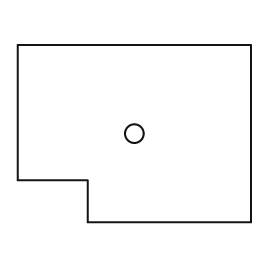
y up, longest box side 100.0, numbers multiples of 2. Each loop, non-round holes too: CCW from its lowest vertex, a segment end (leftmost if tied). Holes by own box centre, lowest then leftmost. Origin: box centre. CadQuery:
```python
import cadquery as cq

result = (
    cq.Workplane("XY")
    .moveTo(-20.0, -38.0)
    .lineTo(50.0, -38.0)
    .lineTo(50.0, 38.0)
    .lineTo(-50.0, 38.0)
    .lineTo(-50.0, -20.0)
    .lineTo(-20.0, -20.0)
    .close()
    .moveTo(0.0, 0.0)
    .circle(4.0)
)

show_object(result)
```